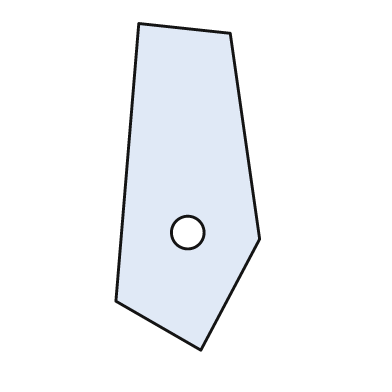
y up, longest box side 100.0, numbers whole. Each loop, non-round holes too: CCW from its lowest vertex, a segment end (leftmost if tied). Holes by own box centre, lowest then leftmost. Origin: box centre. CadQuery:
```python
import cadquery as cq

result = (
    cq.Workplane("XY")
    .moveTo(4.0, -50.0)
    .lineTo(22.0, -16.0)
    .lineTo(13.0, 47.0)
    .lineTo(-15.0, 50.0)
    .lineTo(-22.0, -35.0)
    .close()
    .moveTo(0.0, -14.0)
    .circle(5.0)
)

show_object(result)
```